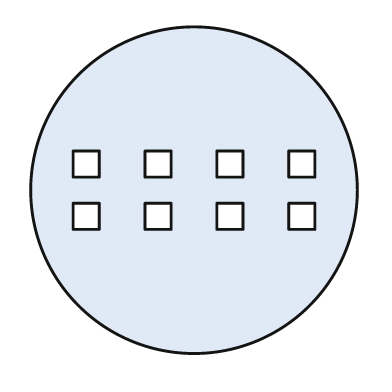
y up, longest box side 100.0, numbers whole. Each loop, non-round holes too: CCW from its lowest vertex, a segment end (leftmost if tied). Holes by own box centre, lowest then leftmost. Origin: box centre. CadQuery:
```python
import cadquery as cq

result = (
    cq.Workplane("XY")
    .moveTo(0.0, 0.0)
    .circle(50.0)
    .moveTo(-37.0, -12.0)
    .lineTo(-29.0, -12.0)
    .lineTo(-29.0, -4.0)
    .lineTo(-37.0, -4.0)
    .close()
    .moveTo(-15.0, -12.0)
    .lineTo(-7.0, -12.0)
    .lineTo(-7.0, -4.0)
    .lineTo(-15.0, -4.0)
    .close()
    .moveTo(7.0, -12.0)
    .lineTo(15.0, -12.0)
    .lineTo(15.0, -4.0)
    .lineTo(7.0, -4.0)
    .close()
    .moveTo(29.0, -12.0)
    .lineTo(37.0, -12.0)
    .lineTo(37.0, -4.0)
    .lineTo(29.0, -4.0)
    .close()
    .moveTo(-37.0, 4.0)
    .lineTo(-29.0, 4.0)
    .lineTo(-29.0, 12.0)
    .lineTo(-37.0, 12.0)
    .close()
    .moveTo(-15.0, 4.0)
    .lineTo(-7.0, 4.0)
    .lineTo(-7.0, 12.0)
    .lineTo(-15.0, 12.0)
    .close()
    .moveTo(7.0, 4.0)
    .lineTo(15.0, 4.0)
    .lineTo(15.0, 12.0)
    .lineTo(7.0, 12.0)
    .close()
    .moveTo(29.0, 4.0)
    .lineTo(37.0, 4.0)
    .lineTo(37.0, 12.0)
    .lineTo(29.0, 12.0)
    .close()
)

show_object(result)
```